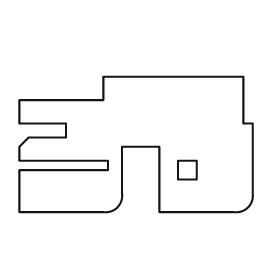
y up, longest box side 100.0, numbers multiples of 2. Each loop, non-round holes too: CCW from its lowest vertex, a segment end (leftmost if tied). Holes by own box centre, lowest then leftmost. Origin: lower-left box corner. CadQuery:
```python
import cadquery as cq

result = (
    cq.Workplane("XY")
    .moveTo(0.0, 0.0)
    .lineTo(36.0, 0.0)
    .threePointArc((42.0, 2.0), (44.0, 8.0))
    .lineTo(44.0, 28.0)
    .lineTo(60.0, 28.0)
    .lineTo(60.0, 0.0)
    .lineTo(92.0, 0.0)
    .threePointArc((98.0, 2.0), (100.0, 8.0))
    .lineTo(100.0, 38.0)
    .lineTo(96.0, 38.0)
    .lineTo(96.0, 58.0)
    .lineTo(36.0, 58.0)
    .lineTo(36.0, 48.0)
    .lineTo(0.0, 48.0)
    .lineTo(0.0, 38.0)
    .lineTo(20.0, 38.0)
    .lineTo(20.0, 32.0)
    .lineTo(4.0, 32.0)
    .lineTo(0.0, 28.0)
    .lineTo(0.0, 22.0)
    .lineTo(38.0, 22.0)
    .lineTo(38.0, 18.0)
    .lineTo(0.0, 18.0)
    .close()
    .moveTo(68.0, 14.0)
    .lineTo(76.0, 14.0)
    .lineTo(76.0, 22.0)
    .lineTo(68.0, 22.0)
    .close()
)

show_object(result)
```